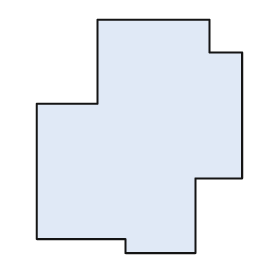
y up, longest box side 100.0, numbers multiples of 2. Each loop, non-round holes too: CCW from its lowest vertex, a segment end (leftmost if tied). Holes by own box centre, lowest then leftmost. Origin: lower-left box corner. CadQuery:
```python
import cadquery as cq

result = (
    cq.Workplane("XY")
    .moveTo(38.0, 0.0)
    .lineTo(68.0, 0.0)
    .lineTo(68.0, 32.0)
    .lineTo(88.0, 32.0)
    .lineTo(88.0, 86.0)
    .lineTo(74.0, 86.0)
    .lineTo(74.0, 100.0)
    .lineTo(26.0, 100.0)
    .lineTo(26.0, 64.0)
    .lineTo(0.0, 64.0)
    .lineTo(0.0, 6.0)
    .lineTo(38.0, 6.0)
    .close()
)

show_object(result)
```